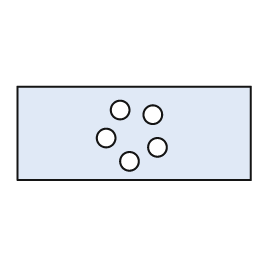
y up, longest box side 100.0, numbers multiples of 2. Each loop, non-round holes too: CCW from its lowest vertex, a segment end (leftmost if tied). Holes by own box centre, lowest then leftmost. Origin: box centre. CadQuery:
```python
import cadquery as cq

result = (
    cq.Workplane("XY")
    .moveTo(-50.0, -20.0)
    .lineTo(50.0, -20.0)
    .lineTo(50.0, 20.0)
    .lineTo(-50.0, 20.0)
    .close()
    .moveTo(-2.0, -12.0)
    .circle(4.0)
    .moveTo(10.0, -6.0)
    .circle(4.0)
    .moveTo(-12.0, -2.0)
    .circle(4.0)
    .moveTo(8.0, 8.0)
    .circle(4.0)
    .moveTo(-6.0, 10.0)
    .circle(4.0)
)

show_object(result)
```